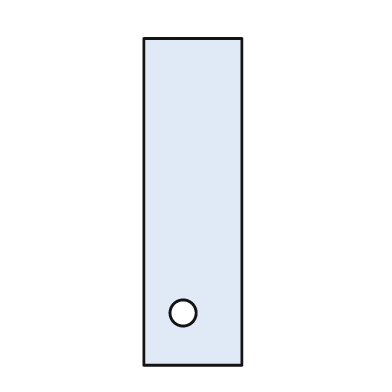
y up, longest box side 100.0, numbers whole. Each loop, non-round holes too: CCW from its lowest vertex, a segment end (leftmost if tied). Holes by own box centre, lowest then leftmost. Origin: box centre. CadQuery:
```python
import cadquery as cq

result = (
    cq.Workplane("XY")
    .moveTo(-15.0, -50.0)
    .lineTo(15.0, -50.0)
    .lineTo(15.0, 50.0)
    .lineTo(-15.0, 50.0)
    .close()
    .moveTo(-3.0, -34.0)
    .circle(4.0)
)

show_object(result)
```